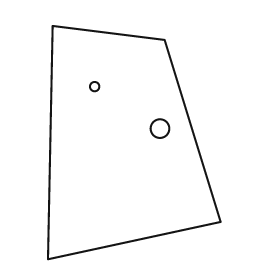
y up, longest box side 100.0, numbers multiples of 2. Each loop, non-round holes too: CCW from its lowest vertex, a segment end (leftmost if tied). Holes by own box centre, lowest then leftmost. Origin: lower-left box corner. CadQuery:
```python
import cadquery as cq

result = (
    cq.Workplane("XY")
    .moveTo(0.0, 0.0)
    .lineTo(74.0, 16.0)
    .lineTo(50.0, 94.0)
    .lineTo(2.0, 100.0)
    .close()
    .moveTo(48.0, 56.0)
    .circle(4.0)
    .moveTo(20.0, 74.0)
    .circle(2.0)
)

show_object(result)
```